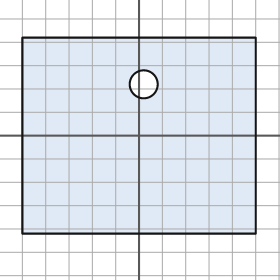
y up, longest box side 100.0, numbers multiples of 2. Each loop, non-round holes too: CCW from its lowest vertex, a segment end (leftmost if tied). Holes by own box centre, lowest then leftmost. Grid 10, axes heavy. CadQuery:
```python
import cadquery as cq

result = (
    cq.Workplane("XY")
    .moveTo(-50.0, -42.0)
    .lineTo(50.0, -42.0)
    .lineTo(50.0, 42.0)
    .lineTo(-50.0, 42.0)
    .close()
    .moveTo(2.0, 22.0)
    .circle(6.0)
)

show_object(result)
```